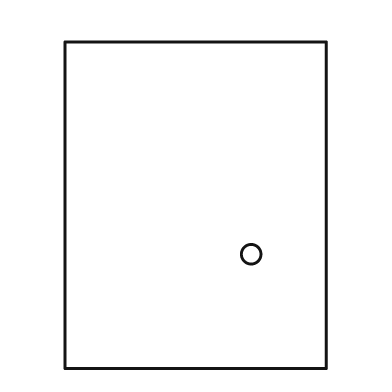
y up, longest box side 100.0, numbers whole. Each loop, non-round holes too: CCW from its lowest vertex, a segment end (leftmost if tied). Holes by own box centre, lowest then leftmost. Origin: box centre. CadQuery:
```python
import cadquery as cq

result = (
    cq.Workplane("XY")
    .moveTo(-40.0, -50.0)
    .lineTo(40.0, -50.0)
    .lineTo(40.0, 50.0)
    .lineTo(-40.0, 50.0)
    .close()
    .moveTo(17.0, -15.0)
    .circle(3.0)
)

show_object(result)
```